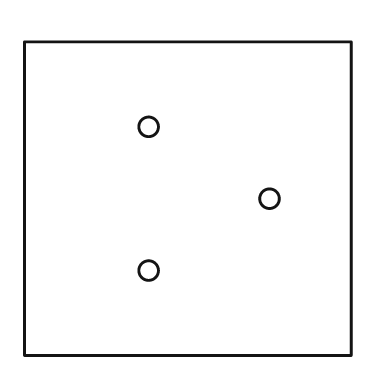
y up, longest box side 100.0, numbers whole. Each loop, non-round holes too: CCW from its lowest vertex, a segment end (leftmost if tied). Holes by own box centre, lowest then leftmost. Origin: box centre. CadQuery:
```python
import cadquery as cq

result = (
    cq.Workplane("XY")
    .moveTo(-50.0, -48.0)
    .lineTo(50.0, -48.0)
    .lineTo(50.0, 48.0)
    .lineTo(-50.0, 48.0)
    .close()
    .moveTo(-12.0, -22.0)
    .circle(3.0)
    .moveTo(25.0, 0.0)
    .circle(3.0)
    .moveTo(-12.0, 22.0)
    .circle(3.0)
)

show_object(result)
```